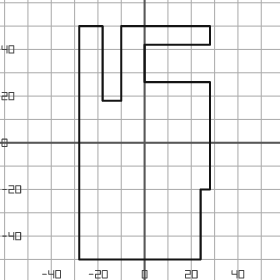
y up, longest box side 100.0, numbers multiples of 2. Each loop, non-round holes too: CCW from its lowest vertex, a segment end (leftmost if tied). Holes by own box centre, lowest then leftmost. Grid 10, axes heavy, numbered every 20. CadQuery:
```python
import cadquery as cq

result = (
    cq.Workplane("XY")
    .moveTo(-28.0, -50.0)
    .lineTo(24.0, -50.0)
    .lineTo(24.0, -20.0)
    .lineTo(28.0, -20.0)
    .lineTo(28.0, 26.0)
    .lineTo(0.0, 26.0)
    .lineTo(0.0, 42.0)
    .lineTo(28.0, 42.0)
    .lineTo(28.0, 50.0)
    .lineTo(-10.0, 50.0)
    .lineTo(-10.0, 18.0)
    .lineTo(-18.0, 18.0)
    .lineTo(-18.0, 50.0)
    .lineTo(-28.0, 50.0)
    .close()
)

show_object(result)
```